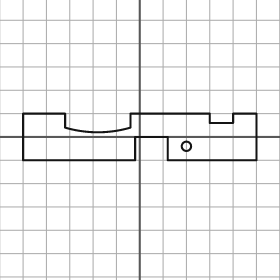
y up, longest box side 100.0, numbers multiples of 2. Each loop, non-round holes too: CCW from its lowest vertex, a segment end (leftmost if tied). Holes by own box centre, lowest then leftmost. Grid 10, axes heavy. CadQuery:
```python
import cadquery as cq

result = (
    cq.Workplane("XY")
    .moveTo(-50.0, -10.0)
    .lineTo(-2.0, -10.0)
    .lineTo(-2.0, 0.0)
    .lineTo(12.0, 0.0)
    .lineTo(12.0, -10.0)
    .lineTo(50.0, -10.0)
    .lineTo(50.0, 10.0)
    .lineTo(40.0, 10.0)
    .lineTo(40.0, 6.0)
    .lineTo(30.0, 6.0)
    .lineTo(30.0, 10.0)
    .lineTo(-4.0, 10.0)
    .lineTo(-4.0, 4.0)
    .threePointArc((-18.0, 2.0), (-32.0, 4.0))
    .lineTo(-32.0, 10.0)
    .lineTo(-50.0, 10.0)
    .close()
    .moveTo(20.0, -4.0)
    .circle(2.0)
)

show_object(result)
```